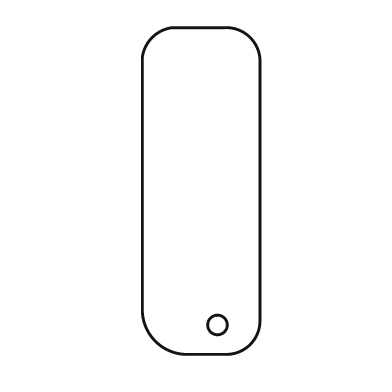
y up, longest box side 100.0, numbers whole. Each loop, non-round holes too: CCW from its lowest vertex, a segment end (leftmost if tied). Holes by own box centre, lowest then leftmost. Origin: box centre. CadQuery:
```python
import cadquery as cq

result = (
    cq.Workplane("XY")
    .moveTo(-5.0, -50.0)
    .lineTo(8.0, -50.0)
    .threePointArc((15.0, -47.0), (18.0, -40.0))
    .lineTo(18.0, 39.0)
    .threePointArc((15.0, 47.0), (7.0, 50.0))
    .lineTo(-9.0, 50.0)
    .threePointArc((-15.0, 47.0), (-18.0, 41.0))
    .lineTo(-18.0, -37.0)
    .threePointArc((-14.0, -46.0), (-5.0, -50.0))
    .close()
    .moveTo(5.0, -41.0)
    .circle(3.0)
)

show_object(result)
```